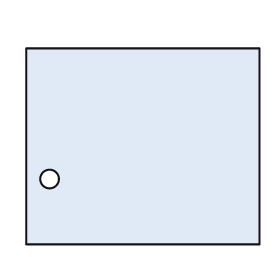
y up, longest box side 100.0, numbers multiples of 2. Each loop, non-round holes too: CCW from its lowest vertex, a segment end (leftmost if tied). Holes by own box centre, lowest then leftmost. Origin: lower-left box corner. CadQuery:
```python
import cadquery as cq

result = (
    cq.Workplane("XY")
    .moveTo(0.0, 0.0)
    .lineTo(100.0, 0.0)
    .lineTo(100.0, 84.0)
    .lineTo(0.0, 84.0)
    .close()
    .moveTo(10.0, 28.0)
    .circle(4.0)
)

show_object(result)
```